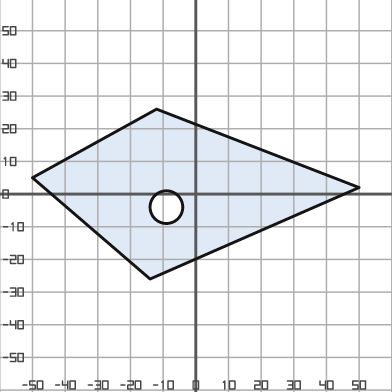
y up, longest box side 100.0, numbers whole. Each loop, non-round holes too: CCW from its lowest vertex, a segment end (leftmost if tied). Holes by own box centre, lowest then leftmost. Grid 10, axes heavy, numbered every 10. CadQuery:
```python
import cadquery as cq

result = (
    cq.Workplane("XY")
    .moveTo(-14.0, -26.0)
    .lineTo(50.0, 2.0)
    .lineTo(-12.0, 26.0)
    .lineTo(-50.0, 5.0)
    .close()
    .moveTo(-9.0, -4.0)
    .circle(5.0)
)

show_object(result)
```